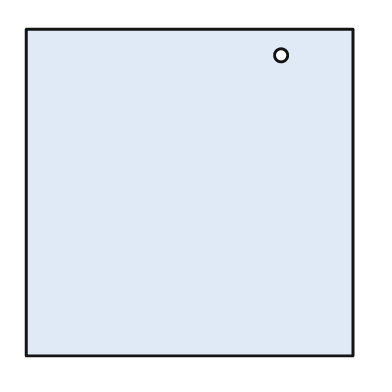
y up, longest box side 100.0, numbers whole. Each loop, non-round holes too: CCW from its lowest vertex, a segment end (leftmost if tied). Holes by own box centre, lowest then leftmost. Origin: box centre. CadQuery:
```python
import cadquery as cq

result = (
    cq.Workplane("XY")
    .moveTo(-50.0, -50.0)
    .lineTo(50.0, -50.0)
    .lineTo(50.0, 50.0)
    .lineTo(-50.0, 50.0)
    .close()
    .moveTo(28.0, 42.0)
    .circle(2.0)
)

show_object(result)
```